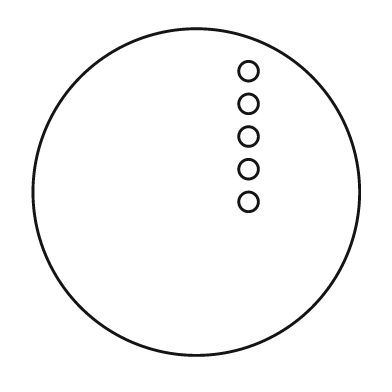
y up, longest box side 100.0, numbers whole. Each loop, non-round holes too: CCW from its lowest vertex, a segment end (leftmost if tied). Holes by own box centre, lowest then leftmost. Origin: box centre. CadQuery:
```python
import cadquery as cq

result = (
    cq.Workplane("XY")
    .moveTo(0.0, 0.0)
    .circle(50.0)
    .moveTo(16.0, -3.0)
    .circle(3.0)
    .moveTo(16.0, 7.0)
    .circle(3.0)
    .moveTo(16.0, 17.0)
    .circle(3.0)
    .moveTo(16.0, 27.0)
    .circle(3.0)
    .moveTo(16.0, 37.0)
    .circle(3.0)
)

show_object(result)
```